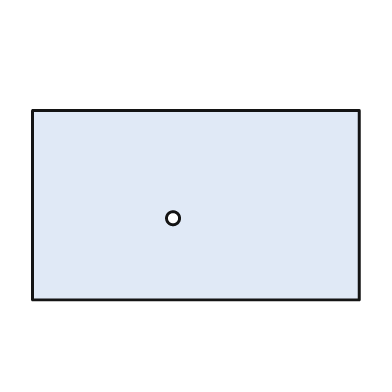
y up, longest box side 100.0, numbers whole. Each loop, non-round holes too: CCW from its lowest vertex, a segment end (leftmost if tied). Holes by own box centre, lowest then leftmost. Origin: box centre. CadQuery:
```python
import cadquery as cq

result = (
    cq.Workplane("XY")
    .moveTo(-50.0, -29.0)
    .lineTo(50.0, -29.0)
    .lineTo(50.0, 29.0)
    .lineTo(-50.0, 29.0)
    .close()
    .moveTo(-7.0, -4.0)
    .circle(2.0)
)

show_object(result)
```